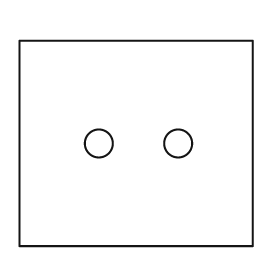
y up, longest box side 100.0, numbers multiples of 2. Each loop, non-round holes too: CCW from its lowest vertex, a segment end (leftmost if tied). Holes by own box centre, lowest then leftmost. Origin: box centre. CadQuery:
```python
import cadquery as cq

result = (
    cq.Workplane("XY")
    .moveTo(-50.0, -44.0)
    .lineTo(50.0, -44.0)
    .lineTo(50.0, 44.0)
    .lineTo(-50.0, 44.0)
    .close()
    .moveTo(-16.0, 0.0)
    .circle(6.0)
    .moveTo(18.0, 0.0)
    .circle(6.0)
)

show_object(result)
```